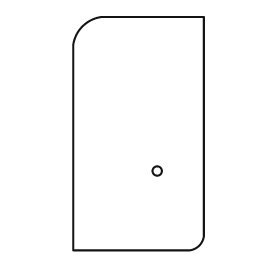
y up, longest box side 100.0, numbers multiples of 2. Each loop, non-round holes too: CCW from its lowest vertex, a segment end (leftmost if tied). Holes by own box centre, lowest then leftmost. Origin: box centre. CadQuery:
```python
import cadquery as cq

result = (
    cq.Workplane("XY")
    .moveTo(-28.0, -50.0)
    .lineTo(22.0, -50.0)
    .threePointArc((26.0, -48.0), (28.0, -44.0))
    .lineTo(28.0, 50.0)
    .lineTo(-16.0, 50.0)
    .threePointArc((-24.0, 46.0), (-28.0, 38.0))
    .close()
    .moveTo(8.0, -16.0)
    .circle(2.0)
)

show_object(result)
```